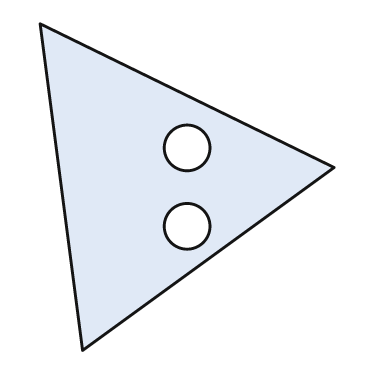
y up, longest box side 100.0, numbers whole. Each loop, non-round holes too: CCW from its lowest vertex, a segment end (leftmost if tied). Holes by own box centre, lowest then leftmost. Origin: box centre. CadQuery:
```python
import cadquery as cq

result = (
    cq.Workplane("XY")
    .moveTo(-32.0, -50.0)
    .lineTo(45.0, 6.0)
    .lineTo(-45.0, 50.0)
    .close()
    .moveTo(0.0, -12.0)
    .circle(7.0)
    .moveTo(0.0, 12.0)
    .circle(7.0)
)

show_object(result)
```